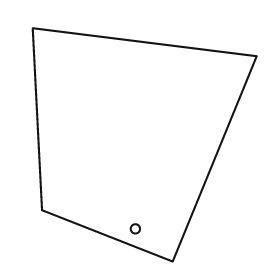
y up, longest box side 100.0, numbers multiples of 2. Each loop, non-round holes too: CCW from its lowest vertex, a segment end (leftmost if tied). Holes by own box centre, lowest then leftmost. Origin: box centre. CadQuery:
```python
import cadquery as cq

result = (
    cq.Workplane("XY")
    .moveTo(12.0, -50.0)
    .lineTo(48.0, 38.0)
    .lineTo(-48.0, 50.0)
    .lineTo(-44.0, -28.0)
    .close()
    .moveTo(-4.0, -36.0)
    .circle(2.0)
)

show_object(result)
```